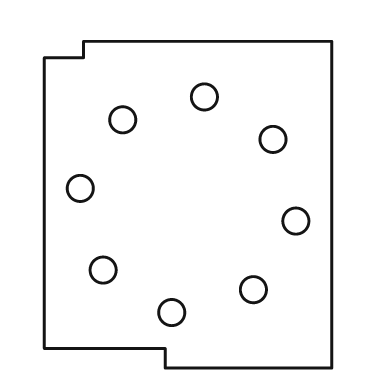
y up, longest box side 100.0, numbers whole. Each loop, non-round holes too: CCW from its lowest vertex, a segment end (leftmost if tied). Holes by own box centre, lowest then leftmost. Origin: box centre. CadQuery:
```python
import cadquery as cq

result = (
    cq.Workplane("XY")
    .moveTo(-7.0, -50.0)
    .lineTo(44.0, -50.0)
    .lineTo(44.0, 50.0)
    .lineTo(-32.0, 50.0)
    .lineTo(-32.0, 45.0)
    .lineTo(-44.0, 45.0)
    .lineTo(-44.0, -44.0)
    .lineTo(-7.0, -44.0)
    .close()
    .moveTo(-5.0, -33.0)
    .circle(4.0)
    .moveTo(20.0, -26.0)
    .circle(4.0)
    .moveTo(-26.0, -20.0)
    .circle(4.0)
    .moveTo(33.0, -5.0)
    .circle(4.0)
    .moveTo(-33.0, 5.0)
    .circle(4.0)
    .moveTo(26.0, 20.0)
    .circle(4.0)
    .moveTo(-20.0, 26.0)
    .circle(4.0)
    .moveTo(5.0, 33.0)
    .circle(4.0)
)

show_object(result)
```